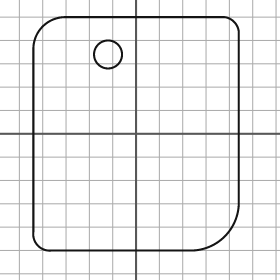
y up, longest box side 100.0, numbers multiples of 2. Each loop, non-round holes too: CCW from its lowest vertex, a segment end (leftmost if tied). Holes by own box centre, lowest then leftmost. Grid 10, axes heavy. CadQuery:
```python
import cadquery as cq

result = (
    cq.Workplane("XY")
    .moveTo(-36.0, -50.0)
    .lineTo(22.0, -50.0)
    .threePointArc((38.0, -44.0), (44.0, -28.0))
    .lineTo(44.0, 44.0)
    .threePointArc((42.0, 48.0), (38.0, 50.0))
    .lineTo(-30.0, 50.0)
    .threePointArc((-40.0, 46.0), (-44.0, 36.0))
    .lineTo(-44.0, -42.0)
    .threePointArc((-42.0, -48.0), (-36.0, -50.0))
    .close()
    .moveTo(-12.0, 34.0)
    .circle(6.0)
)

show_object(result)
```